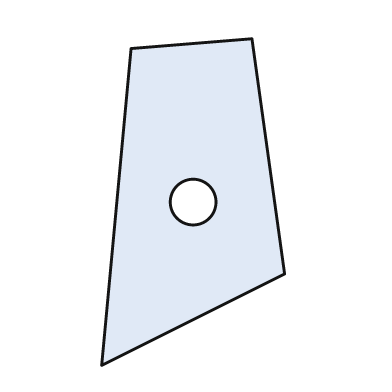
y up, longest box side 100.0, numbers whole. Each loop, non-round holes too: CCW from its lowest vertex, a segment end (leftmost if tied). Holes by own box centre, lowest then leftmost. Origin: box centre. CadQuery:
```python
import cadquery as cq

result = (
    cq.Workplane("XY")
    .moveTo(-28.0, -50.0)
    .lineTo(28.0, -22.0)
    .lineTo(18.0, 50.0)
    .lineTo(-19.0, 47.0)
    .close()
    .moveTo(0.0, 0.0)
    .circle(7.0)
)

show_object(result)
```